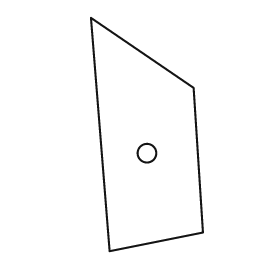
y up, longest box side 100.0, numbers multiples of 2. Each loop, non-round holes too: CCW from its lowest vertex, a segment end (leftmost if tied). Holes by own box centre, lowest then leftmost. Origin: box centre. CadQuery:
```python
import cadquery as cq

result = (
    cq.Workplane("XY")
    .moveTo(-16.0, -50.0)
    .lineTo(24.0, -42.0)
    .lineTo(20.0, 20.0)
    .lineTo(-24.0, 50.0)
    .close()
    .moveTo(0.0, -8.0)
    .circle(4.0)
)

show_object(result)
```